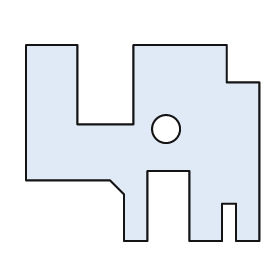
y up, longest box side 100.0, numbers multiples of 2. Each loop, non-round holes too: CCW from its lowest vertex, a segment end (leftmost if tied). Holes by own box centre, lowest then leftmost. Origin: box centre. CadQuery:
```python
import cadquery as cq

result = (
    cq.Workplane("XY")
    .moveTo(-8.0, -42.0)
    .lineTo(2.0, -42.0)
    .lineTo(2.0, -12.0)
    .lineTo(20.0, -12.0)
    .lineTo(20.0, -42.0)
    .lineTo(34.0, -42.0)
    .lineTo(34.0, -26.0)
    .lineTo(40.0, -26.0)
    .lineTo(40.0, -42.0)
    .lineTo(50.0, -42.0)
    .lineTo(50.0, 26.0)
    .lineTo(36.0, 26.0)
    .lineTo(36.0, 42.0)
    .lineTo(-4.0, 42.0)
    .lineTo(-4.0, 8.0)
    .lineTo(-28.0, 8.0)
    .lineTo(-28.0, 42.0)
    .lineTo(-50.0, 42.0)
    .lineTo(-50.0, -16.0)
    .lineTo(-14.0, -16.0)
    .lineTo(-8.0, -22.0)
    .close()
    .moveTo(10.0, 6.0)
    .circle(6.0)
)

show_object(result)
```